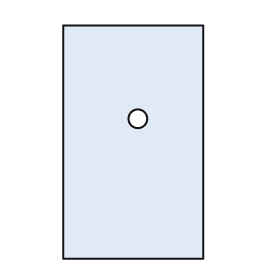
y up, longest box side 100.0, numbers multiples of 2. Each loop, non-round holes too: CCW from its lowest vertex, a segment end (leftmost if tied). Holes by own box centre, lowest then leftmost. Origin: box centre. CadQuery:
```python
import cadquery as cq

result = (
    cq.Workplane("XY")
    .moveTo(-30.0, -50.0)
    .lineTo(30.0, -50.0)
    .lineTo(30.0, 50.0)
    .lineTo(-30.0, 50.0)
    .close()
    .moveTo(2.0, 10.0)
    .circle(4.0)
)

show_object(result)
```